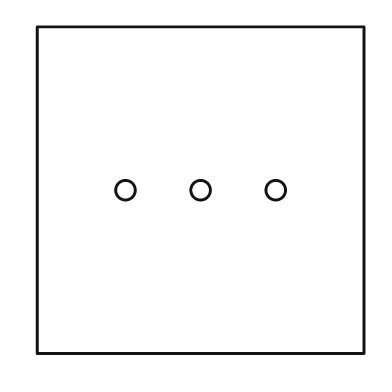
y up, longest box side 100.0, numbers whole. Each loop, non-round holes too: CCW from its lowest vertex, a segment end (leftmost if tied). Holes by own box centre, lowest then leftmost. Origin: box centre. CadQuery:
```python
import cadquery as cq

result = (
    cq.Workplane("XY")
    .moveTo(-50.0, -50.0)
    .lineTo(50.0, -50.0)
    .lineTo(50.0, 50.0)
    .lineTo(-50.0, 50.0)
    .close()
    .moveTo(-23.0, 0.0)
    .circle(3.0)
    .moveTo(0.0, 0.0)
    .circle(3.0)
    .moveTo(23.0, 0.0)
    .circle(3.0)
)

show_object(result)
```